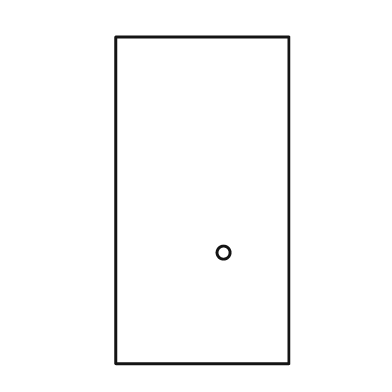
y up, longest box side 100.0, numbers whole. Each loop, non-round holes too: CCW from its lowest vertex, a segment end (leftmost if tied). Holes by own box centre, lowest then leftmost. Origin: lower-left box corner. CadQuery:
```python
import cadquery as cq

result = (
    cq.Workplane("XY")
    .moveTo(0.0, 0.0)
    .lineTo(53.0, 0.0)
    .lineTo(53.0, 100.0)
    .lineTo(0.0, 100.0)
    .close()
    .moveTo(33.0, 34.0)
    .circle(2.0)
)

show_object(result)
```